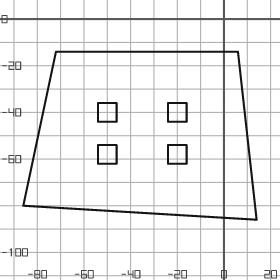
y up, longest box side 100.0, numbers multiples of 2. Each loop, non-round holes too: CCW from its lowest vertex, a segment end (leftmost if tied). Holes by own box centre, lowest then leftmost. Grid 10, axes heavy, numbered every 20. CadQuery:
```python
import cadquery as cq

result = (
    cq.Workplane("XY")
    .moveTo(14.0, -86.0)
    .lineTo(6.0, -14.0)
    .lineTo(-72.0, -14.0)
    .lineTo(-86.0, -80.0)
    .close()
    .moveTo(-54.0, -62.0)
    .lineTo(-46.0, -62.0)
    .lineTo(-46.0, -54.0)
    .lineTo(-54.0, -54.0)
    .close()
    .moveTo(-24.0, -62.0)
    .lineTo(-16.0, -62.0)
    .lineTo(-16.0, -54.0)
    .lineTo(-24.0, -54.0)
    .close()
    .moveTo(-54.0, -44.0)
    .lineTo(-46.0, -44.0)
    .lineTo(-46.0, -36.0)
    .lineTo(-54.0, -36.0)
    .close()
    .moveTo(-24.0, -44.0)
    .lineTo(-16.0, -44.0)
    .lineTo(-16.0, -36.0)
    .lineTo(-24.0, -36.0)
    .close()
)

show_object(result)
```